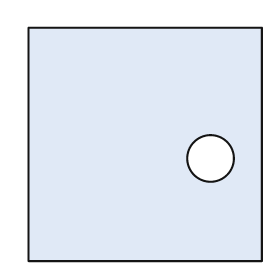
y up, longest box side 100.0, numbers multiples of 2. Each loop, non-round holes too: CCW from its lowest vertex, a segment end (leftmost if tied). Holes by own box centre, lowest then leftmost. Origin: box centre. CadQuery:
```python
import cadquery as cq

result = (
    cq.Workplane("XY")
    .moveTo(-50.0, -50.0)
    .lineTo(50.0, -50.0)
    .lineTo(50.0, 50.0)
    .lineTo(-50.0, 50.0)
    .close()
    .moveTo(28.0, -6.0)
    .circle(10.0)
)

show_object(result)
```